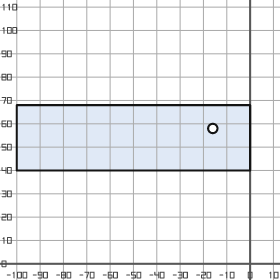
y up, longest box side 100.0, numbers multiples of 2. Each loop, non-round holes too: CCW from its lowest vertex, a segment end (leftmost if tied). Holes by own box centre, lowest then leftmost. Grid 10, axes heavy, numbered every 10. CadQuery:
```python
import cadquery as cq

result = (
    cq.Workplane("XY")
    .moveTo(-100.0, 40.0)
    .lineTo(0.0, 40.0)
    .lineTo(0.0, 68.0)
    .lineTo(-100.0, 68.0)
    .close()
    .moveTo(-16.0, 58.0)
    .circle(2.0)
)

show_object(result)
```